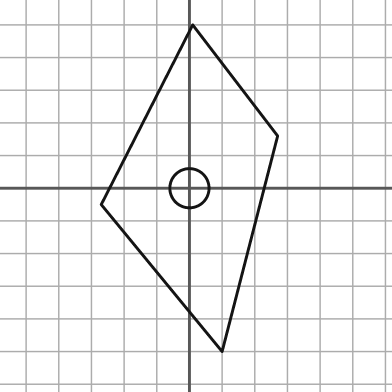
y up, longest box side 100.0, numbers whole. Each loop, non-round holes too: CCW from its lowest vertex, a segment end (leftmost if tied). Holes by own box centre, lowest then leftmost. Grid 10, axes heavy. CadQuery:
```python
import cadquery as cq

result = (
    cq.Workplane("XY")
    .moveTo(10.0, -50.0)
    .lineTo(27.0, 16.0)
    .lineTo(1.0, 50.0)
    .lineTo(-27.0, -5.0)
    .close()
    .moveTo(0.0, 0.0)
    .circle(6.0)
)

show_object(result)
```